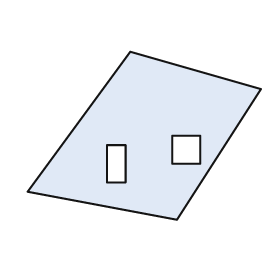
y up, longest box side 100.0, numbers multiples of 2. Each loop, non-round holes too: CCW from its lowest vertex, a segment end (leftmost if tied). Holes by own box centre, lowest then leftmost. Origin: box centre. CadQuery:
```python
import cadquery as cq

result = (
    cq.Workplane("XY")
    .moveTo(14.0, -36.0)
    .lineTo(50.0, 20.0)
    .lineTo(-6.0, 36.0)
    .lineTo(-50.0, -24.0)
    .close()
    .moveTo(-16.0, -20.0)
    .lineTo(-8.0, -20.0)
    .lineTo(-8.0, -4.0)
    .lineTo(-16.0, -4.0)
    .close()
    .moveTo(12.0, -12.0)
    .lineTo(24.0, -12.0)
    .lineTo(24.0, 0.0)
    .lineTo(12.0, 0.0)
    .close()
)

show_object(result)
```